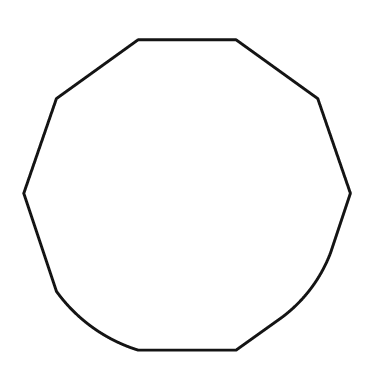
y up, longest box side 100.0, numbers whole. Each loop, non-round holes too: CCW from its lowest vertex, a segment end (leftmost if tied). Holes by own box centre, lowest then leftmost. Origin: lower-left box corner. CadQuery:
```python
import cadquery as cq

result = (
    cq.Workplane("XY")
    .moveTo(35.0, 0.0)
    .lineTo(65.0, 0.0)
    .lineTo(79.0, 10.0)
    .threePointArc((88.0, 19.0), (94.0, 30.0))
    .lineTo(100.0, 48.0)
    .lineTo(90.0, 77.0)
    .lineTo(65.0, 95.0)
    .lineTo(35.0, 95.0)
    .lineTo(10.0, 77.0)
    .lineTo(0.0, 48.0)
    .lineTo(10.0, 18.0)
    .threePointArc((21.0, 7.0), (35.0, 0.0))
    .close()
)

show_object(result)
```